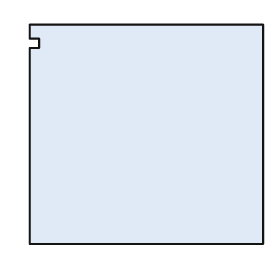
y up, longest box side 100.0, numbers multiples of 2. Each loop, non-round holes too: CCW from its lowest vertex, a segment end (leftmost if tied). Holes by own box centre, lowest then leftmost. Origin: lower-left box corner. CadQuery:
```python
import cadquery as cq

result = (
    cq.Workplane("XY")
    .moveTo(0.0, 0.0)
    .lineTo(100.0, 0.0)
    .lineTo(100.0, 94.0)
    .lineTo(0.0, 94.0)
    .lineTo(0.0, 88.0)
    .lineTo(4.0, 88.0)
    .lineTo(4.0, 84.0)
    .lineTo(0.0, 84.0)
    .close()
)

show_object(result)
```